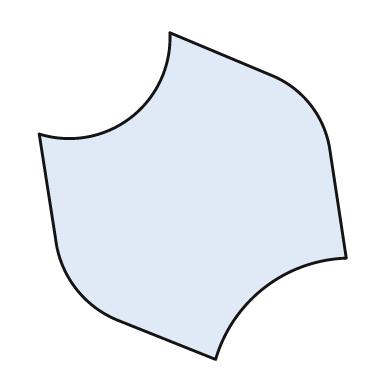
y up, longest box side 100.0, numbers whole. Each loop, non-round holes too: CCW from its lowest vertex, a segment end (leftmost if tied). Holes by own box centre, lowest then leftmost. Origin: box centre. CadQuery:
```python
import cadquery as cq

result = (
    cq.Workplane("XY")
    .moveTo(7.0, -50.0)
    .threePointArc((22.0, -28.0), (47.0, -19.0))
    .lineTo(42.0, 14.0)
    .threePointArc((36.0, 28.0), (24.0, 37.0))
    .lineTo(-7.0, 50.0)
    .threePointArc((-19.0, 24.0), (-47.0, 19.0))
    .lineTo(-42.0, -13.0)
    .threePointArc((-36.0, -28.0), (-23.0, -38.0))
    .close()
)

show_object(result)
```